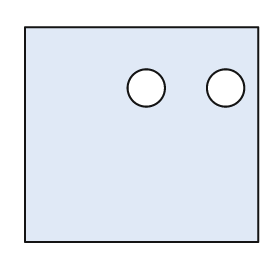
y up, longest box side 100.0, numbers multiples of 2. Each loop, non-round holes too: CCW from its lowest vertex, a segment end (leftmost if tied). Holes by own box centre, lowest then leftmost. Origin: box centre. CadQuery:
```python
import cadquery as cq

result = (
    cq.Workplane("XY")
    .moveTo(-50.0, -46.0)
    .lineTo(50.0, -46.0)
    .lineTo(50.0, 46.0)
    .lineTo(-50.0, 46.0)
    .close()
    .moveTo(2.0, 20.0)
    .circle(8.0)
    .moveTo(36.0, 20.0)
    .circle(8.0)
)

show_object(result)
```